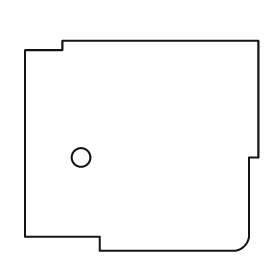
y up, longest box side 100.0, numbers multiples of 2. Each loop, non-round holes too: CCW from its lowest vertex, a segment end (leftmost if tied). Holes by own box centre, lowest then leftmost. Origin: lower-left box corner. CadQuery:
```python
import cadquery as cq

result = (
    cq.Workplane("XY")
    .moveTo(32.0, 0.0)
    .lineTo(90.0, 0.0)
    .threePointArc((94.0, 2.0), (96.0, 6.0))
    .lineTo(96.0, 40.0)
    .lineTo(100.0, 40.0)
    .lineTo(100.0, 90.0)
    .lineTo(16.0, 90.0)
    .lineTo(16.0, 86.0)
    .lineTo(0.0, 86.0)
    .lineTo(0.0, 6.0)
    .lineTo(32.0, 6.0)
    .close()
    .moveTo(24.0, 40.0)
    .circle(4.0)
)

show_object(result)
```